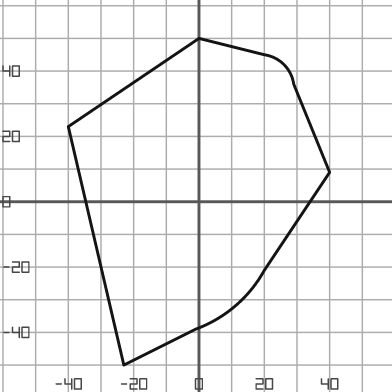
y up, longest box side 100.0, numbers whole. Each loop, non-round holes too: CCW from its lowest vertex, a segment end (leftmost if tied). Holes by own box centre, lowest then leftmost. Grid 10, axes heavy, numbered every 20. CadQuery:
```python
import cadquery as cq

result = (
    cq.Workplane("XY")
    .moveTo(-23.0, -50.0)
    .lineTo(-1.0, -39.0)
    .threePointArc((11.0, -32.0), (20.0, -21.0))
    .lineTo(40.0, 9.0)
    .lineTo(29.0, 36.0)
    .threePointArc((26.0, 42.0), (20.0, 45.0))
    .lineTo(0.0, 50.0)
    .lineTo(-40.0, 23.0)
    .close()
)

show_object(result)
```